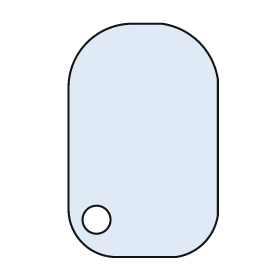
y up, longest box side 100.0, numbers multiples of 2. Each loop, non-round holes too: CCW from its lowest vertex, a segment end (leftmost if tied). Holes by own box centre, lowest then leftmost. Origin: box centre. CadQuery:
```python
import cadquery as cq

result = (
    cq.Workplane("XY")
    .moveTo(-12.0, -50.0)
    .lineTo(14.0, -50.0)
    .threePointArc((26.0, -44.0), (32.0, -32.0))
    .lineTo(32.0, 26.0)
    .threePointArc((24.0, 42.0), (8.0, 50.0))
    .lineTo(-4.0, 50.0)
    .threePointArc((-24.0, 42.0), (-32.0, 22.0))
    .lineTo(-32.0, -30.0)
    .threePointArc((-26.0, -44.0), (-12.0, -50.0))
    .close()
    .moveTo(-20.0, -34.0)
    .circle(6.0)
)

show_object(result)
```